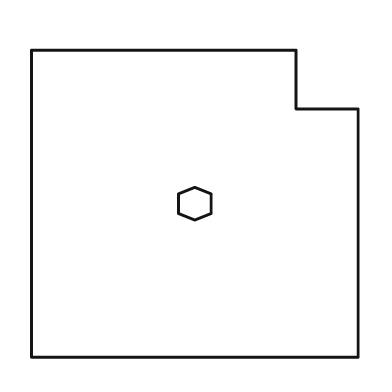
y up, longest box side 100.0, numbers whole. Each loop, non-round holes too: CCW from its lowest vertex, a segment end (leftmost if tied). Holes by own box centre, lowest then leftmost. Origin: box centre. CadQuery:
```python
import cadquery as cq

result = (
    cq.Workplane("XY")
    .moveTo(-50.0, -47.0)
    .lineTo(50.0, -47.0)
    .lineTo(50.0, 29.0)
    .lineTo(31.0, 29.0)
    .lineTo(31.0, 47.0)
    .lineTo(-50.0, 47.0)
    .close()
    .moveTo(0.0, -5.0)
    .lineTo(5.0, -3.0)
    .lineTo(5.0, 3.0)
    .lineTo(0.0, 5.0)
    .lineTo(-5.0, 3.0)
    .lineTo(-5.0, -3.0)
    .close()
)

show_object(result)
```